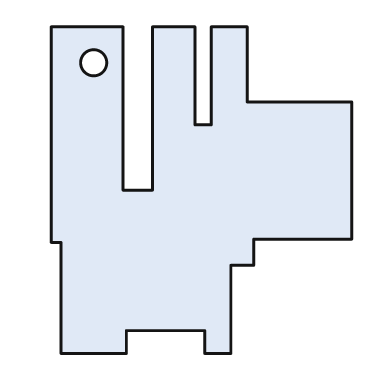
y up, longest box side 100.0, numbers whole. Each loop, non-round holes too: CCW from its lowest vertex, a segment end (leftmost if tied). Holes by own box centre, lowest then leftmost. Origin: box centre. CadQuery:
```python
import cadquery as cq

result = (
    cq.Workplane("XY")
    .moveTo(-43.0, -50.0)
    .lineTo(-23.0, -50.0)
    .lineTo(-23.0, -43.0)
    .lineTo(1.0, -43.0)
    .lineTo(1.0, -50.0)
    .lineTo(9.0, -50.0)
    .lineTo(9.0, -23.0)
    .lineTo(16.0, -23.0)
    .lineTo(16.0, -15.0)
    .lineTo(46.0, -15.0)
    .lineTo(46.0, 27.0)
    .lineTo(14.0, 27.0)
    .lineTo(14.0, 50.0)
    .lineTo(3.0, 50.0)
    .lineTo(3.0, 20.0)
    .lineTo(-2.0, 20.0)
    .lineTo(-2.0, 50.0)
    .lineTo(-15.0, 50.0)
    .lineTo(-15.0, 0.0)
    .lineTo(-24.0, 0.0)
    .lineTo(-24.0, 50.0)
    .lineTo(-46.0, 50.0)
    .lineTo(-46.0, -16.0)
    .lineTo(-43.0, -16.0)
    .close()
    .moveTo(-33.0, 39.0)
    .circle(4.0)
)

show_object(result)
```